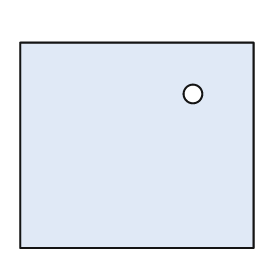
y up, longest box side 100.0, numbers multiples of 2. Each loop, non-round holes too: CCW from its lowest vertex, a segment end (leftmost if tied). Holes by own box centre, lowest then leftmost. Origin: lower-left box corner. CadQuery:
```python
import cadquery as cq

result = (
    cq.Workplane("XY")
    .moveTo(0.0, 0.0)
    .lineTo(100.0, 0.0)
    .lineTo(100.0, 88.0)
    .lineTo(0.0, 88.0)
    .close()
    .moveTo(74.0, 66.0)
    .circle(4.0)
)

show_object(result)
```